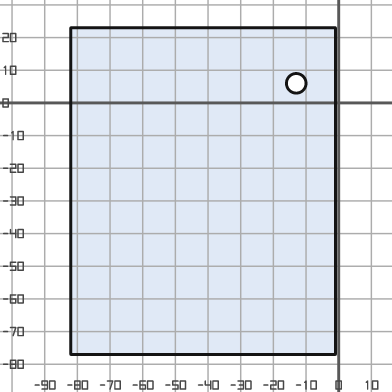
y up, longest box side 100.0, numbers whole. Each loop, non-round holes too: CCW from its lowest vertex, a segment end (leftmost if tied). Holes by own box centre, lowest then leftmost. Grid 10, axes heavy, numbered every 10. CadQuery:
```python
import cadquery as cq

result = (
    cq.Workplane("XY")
    .moveTo(-82.0, -77.0)
    .lineTo(-1.0, -77.0)
    .lineTo(-1.0, 23.0)
    .lineTo(-82.0, 23.0)
    .close()
    .moveTo(-13.0, 6.0)
    .circle(3.0)
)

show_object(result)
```